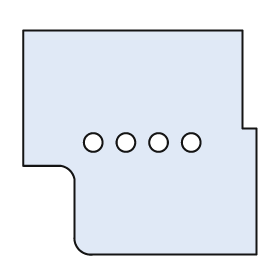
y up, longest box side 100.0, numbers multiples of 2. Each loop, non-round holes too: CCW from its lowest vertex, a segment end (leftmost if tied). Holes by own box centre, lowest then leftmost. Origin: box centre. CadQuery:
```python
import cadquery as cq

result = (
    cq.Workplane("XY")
    .moveTo(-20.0, -48.0)
    .lineTo(50.0, -48.0)
    .lineTo(50.0, 6.0)
    .lineTo(44.0, 6.0)
    .lineTo(44.0, 48.0)
    .lineTo(-50.0, 48.0)
    .lineTo(-50.0, -10.0)
    .lineTo(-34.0, -10.0)
    .threePointArc((-30.0, -12.0), (-28.0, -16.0))
    .lineTo(-28.0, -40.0)
    .threePointArc((-26.0, -46.0), (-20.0, -48.0))
    .close()
    .moveTo(-20.0, 0.0)
    .circle(4.0)
    .moveTo(-6.0, 0.0)
    .circle(4.0)
    .moveTo(8.0, 0.0)
    .circle(4.0)
    .moveTo(22.0, 0.0)
    .circle(4.0)
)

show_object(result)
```